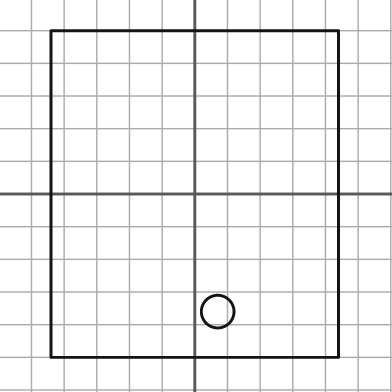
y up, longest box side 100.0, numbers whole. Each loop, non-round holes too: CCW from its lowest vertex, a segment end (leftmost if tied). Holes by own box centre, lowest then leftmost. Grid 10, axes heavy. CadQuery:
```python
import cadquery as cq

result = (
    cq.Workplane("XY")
    .moveTo(-44.0, -50.0)
    .lineTo(44.0, -50.0)
    .lineTo(44.0, 50.0)
    .lineTo(-44.0, 50.0)
    .close()
    .moveTo(7.0, -36.0)
    .circle(5.0)
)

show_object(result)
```